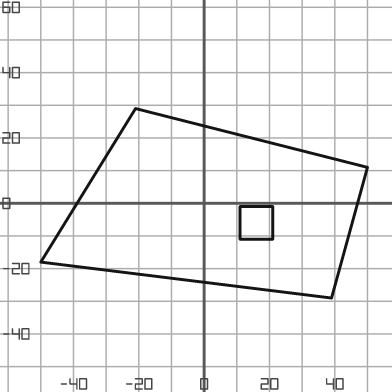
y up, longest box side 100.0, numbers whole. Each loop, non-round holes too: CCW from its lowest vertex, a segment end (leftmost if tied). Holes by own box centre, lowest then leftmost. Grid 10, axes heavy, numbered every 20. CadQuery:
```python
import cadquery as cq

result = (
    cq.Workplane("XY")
    .moveTo(39.0, -29.0)
    .lineTo(50.0, 11.0)
    .lineTo(-21.0, 29.0)
    .lineTo(-50.0, -18.0)
    .close()
    .moveTo(11.0, -11.0)
    .lineTo(21.0, -11.0)
    .lineTo(21.0, -1.0)
    .lineTo(11.0, -1.0)
    .close()
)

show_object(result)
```